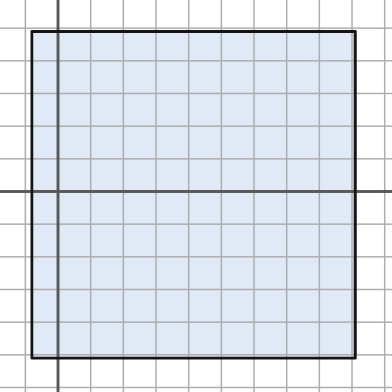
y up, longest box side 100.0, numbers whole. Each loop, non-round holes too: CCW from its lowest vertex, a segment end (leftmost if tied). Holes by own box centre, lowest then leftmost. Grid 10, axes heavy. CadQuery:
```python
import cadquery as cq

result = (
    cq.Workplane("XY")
    .moveTo(-8.0, -51.0)
    .lineTo(91.0, -51.0)
    .lineTo(91.0, 49.0)
    .lineTo(-8.0, 49.0)
    .close()
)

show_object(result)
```